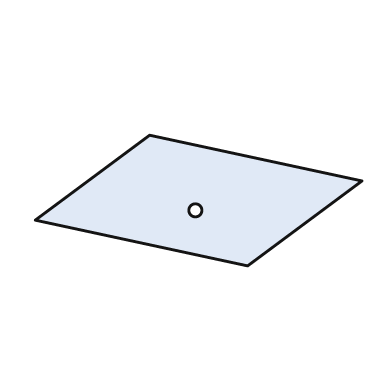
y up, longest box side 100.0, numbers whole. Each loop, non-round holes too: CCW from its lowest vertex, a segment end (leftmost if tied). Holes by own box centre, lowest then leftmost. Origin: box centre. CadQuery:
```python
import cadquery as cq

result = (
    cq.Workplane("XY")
    .moveTo(15.0, -20.0)
    .lineTo(50.0, 6.0)
    .lineTo(-15.0, 20.0)
    .lineTo(-50.0, -6.0)
    .close()
    .moveTo(-1.0, -3.0)
    .circle(2.0)
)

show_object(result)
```